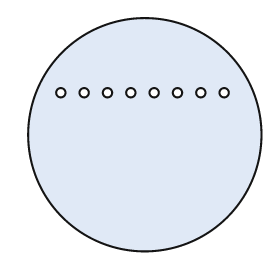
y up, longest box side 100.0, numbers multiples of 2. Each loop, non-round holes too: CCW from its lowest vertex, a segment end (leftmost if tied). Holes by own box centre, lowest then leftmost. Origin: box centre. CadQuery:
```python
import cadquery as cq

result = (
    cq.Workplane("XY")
    .moveTo(0.0, 0.0)
    .circle(50.0)
    .moveTo(-36.0, 18.0)
    .circle(2.0)
    .moveTo(-26.0, 18.0)
    .circle(2.0)
    .moveTo(-16.0, 18.0)
    .circle(2.0)
    .moveTo(-6.0, 18.0)
    .circle(2.0)
    .moveTo(4.0, 18.0)
    .circle(2.0)
    .moveTo(14.0, 18.0)
    .circle(2.0)
    .moveTo(24.0, 18.0)
    .circle(2.0)
    .moveTo(34.0, 18.0)
    .circle(2.0)
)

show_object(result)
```